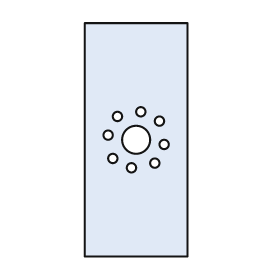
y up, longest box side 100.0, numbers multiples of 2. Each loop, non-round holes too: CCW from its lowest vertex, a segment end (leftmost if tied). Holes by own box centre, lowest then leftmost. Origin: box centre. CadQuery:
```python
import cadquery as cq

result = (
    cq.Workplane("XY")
    .moveTo(-22.0, -50.0)
    .lineTo(22.0, -50.0)
    .lineTo(22.0, 50.0)
    .lineTo(-22.0, 50.0)
    .close()
    .moveTo(-2.0, -12.0)
    .circle(2.0)
    .moveTo(8.0, -10.0)
    .circle(2.0)
    .moveTo(-10.0, -8.0)
    .circle(2.0)
    .moveTo(12.0, -2.0)
    .circle(2.0)
    .moveTo(0.0, 0.0)
    .circle(6.0)
    .moveTo(-12.0, 2.0)
    .circle(2.0)
    .moveTo(10.0, 8.0)
    .circle(2.0)
    .moveTo(-8.0, 10.0)
    .circle(2.0)
    .moveTo(2.0, 12.0)
    .circle(2.0)
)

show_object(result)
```